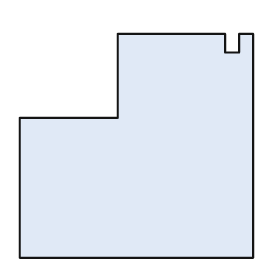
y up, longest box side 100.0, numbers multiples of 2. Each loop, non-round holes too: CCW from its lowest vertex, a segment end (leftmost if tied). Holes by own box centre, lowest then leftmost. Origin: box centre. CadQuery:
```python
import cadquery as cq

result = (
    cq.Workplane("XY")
    .moveTo(-50.0, -48.0)
    .lineTo(50.0, -48.0)
    .lineTo(50.0, 48.0)
    .lineTo(44.0, 48.0)
    .lineTo(44.0, 40.0)
    .lineTo(38.0, 40.0)
    .lineTo(38.0, 48.0)
    .lineTo(-8.0, 48.0)
    .lineTo(-8.0, 12.0)
    .lineTo(-50.0, 12.0)
    .close()
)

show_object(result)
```